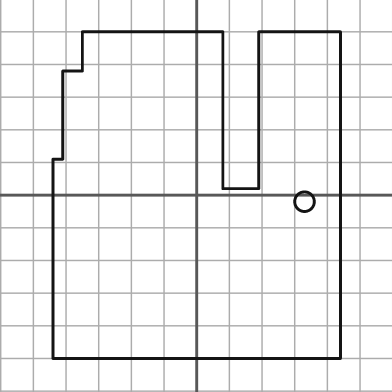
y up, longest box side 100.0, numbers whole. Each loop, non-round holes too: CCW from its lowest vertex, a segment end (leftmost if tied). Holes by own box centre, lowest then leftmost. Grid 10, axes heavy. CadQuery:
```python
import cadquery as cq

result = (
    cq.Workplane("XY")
    .moveTo(-44.0, -50.0)
    .lineTo(44.0, -50.0)
    .lineTo(44.0, 50.0)
    .lineTo(19.0, 50.0)
    .lineTo(19.0, 2.0)
    .lineTo(8.0, 2.0)
    .lineTo(8.0, 50.0)
    .lineTo(-35.0, 50.0)
    .lineTo(-35.0, 38.0)
    .lineTo(-41.0, 38.0)
    .lineTo(-41.0, 11.0)
    .lineTo(-44.0, 11.0)
    .close()
    .moveTo(33.0, -2.0)
    .circle(3.0)
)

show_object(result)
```